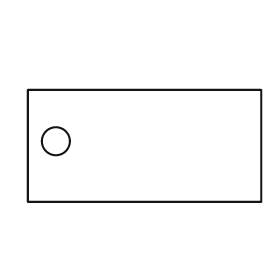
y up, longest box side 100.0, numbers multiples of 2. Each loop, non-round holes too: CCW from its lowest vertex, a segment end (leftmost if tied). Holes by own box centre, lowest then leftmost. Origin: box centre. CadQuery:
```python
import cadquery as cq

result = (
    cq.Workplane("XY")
    .moveTo(-50.0, -24.0)
    .lineTo(50.0, -24.0)
    .lineTo(50.0, 24.0)
    .lineTo(-50.0, 24.0)
    .close()
    .moveTo(-38.0, 2.0)
    .circle(6.0)
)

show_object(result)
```